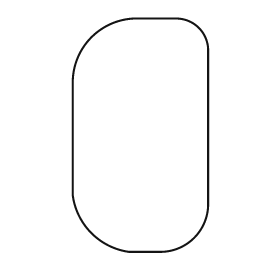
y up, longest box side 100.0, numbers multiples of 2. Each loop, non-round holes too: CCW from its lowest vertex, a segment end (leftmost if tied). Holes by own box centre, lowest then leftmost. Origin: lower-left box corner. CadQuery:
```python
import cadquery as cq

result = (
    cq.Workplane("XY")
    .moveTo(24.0, 0.0)
    .lineTo(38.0, 0.0)
    .threePointArc((52.0, 6.0), (58.0, 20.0))
    .lineTo(58.0, 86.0)
    .threePointArc((54.0, 96.0), (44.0, 100.0))
    .lineTo(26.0, 100.0)
    .threePointArc((8.0, 92.0), (0.0, 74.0))
    .lineTo(0.0, 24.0)
    .threePointArc((8.0, 8.0), (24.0, 0.0))
    .close()
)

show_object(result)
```